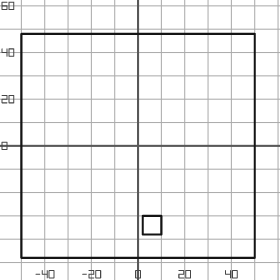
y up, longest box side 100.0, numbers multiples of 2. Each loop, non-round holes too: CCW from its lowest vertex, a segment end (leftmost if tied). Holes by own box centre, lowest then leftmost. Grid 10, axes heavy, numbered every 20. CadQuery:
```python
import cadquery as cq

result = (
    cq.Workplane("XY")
    .moveTo(-50.0, -48.0)
    .lineTo(50.0, -48.0)
    .lineTo(50.0, 48.0)
    .lineTo(-50.0, 48.0)
    .close()
    .moveTo(2.0, -38.0)
    .lineTo(10.0, -38.0)
    .lineTo(10.0, -30.0)
    .lineTo(2.0, -30.0)
    .close()
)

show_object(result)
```